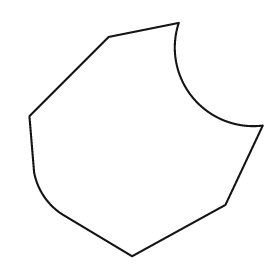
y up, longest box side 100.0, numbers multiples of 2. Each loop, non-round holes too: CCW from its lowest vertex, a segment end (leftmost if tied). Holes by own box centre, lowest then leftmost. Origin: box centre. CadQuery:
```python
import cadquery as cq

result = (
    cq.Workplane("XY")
    .moveTo(-6.0, -50.0)
    .lineTo(34.0, -28.0)
    .lineTo(50.0, 6.0)
    .threePointArc((20.0, 18.0), (14.0, 50.0))
    .lineTo(-16.0, 44.0)
    .lineTo(-50.0, 10.0)
    .lineTo(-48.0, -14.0)
    .threePointArc((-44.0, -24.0), (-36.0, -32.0))
    .close()
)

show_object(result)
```